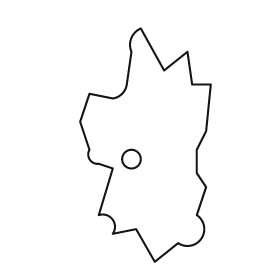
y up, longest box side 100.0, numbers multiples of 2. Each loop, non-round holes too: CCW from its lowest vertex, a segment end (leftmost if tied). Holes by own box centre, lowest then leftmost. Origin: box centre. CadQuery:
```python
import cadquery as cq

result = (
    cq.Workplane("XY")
    .moveTo(4.0, -50.0)
    .lineTo(14.0, -42.0)
    .threePointArc((24.0, -40.0), (22.0, -30.0))
    .lineTo(26.0, -18.0)
    .lineTo(22.0, -12.0)
    .lineTo(22.0, -2.0)
    .lineTo(26.0, 6.0)
    .lineTo(28.0, 26.0)
    .lineTo(20.0, 26.0)
    .lineTo(18.0, 40.0)
    .lineTo(8.0, 32.0)
    .lineTo(-2.0, 50.0)
    .threePointArc((-6.0, 46.0), (-6.0, 40.0))
    .lineTo(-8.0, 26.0)
    .threePointArc((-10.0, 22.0), (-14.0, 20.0))
    .lineTo(-24.0, 22.0)
    .lineTo(-28.0, 10.0)
    .lineTo(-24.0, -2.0)
    .threePointArc((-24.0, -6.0), (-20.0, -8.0))
    .lineTo(-14.0, -10.0)
    .lineTo(-20.0, -30.0)
    .threePointArc((-14.0, -32.0), (-14.0, -38.0))
    .lineTo(-4.0, -36.0)
    .close()
    .moveTo(-6.0, -6.0)
    .circle(4.0)
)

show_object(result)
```